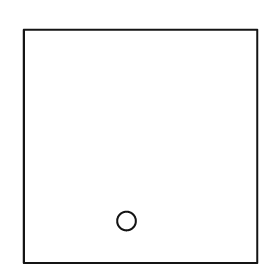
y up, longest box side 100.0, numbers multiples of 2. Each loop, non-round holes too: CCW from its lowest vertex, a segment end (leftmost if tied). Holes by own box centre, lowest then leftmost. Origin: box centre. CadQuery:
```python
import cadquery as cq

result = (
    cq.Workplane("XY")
    .moveTo(-50.0, -50.0)
    .lineTo(50.0, -50.0)
    .lineTo(50.0, 50.0)
    .lineTo(-50.0, 50.0)
    .close()
    .moveTo(-6.0, -32.0)
    .circle(4.0)
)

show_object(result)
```